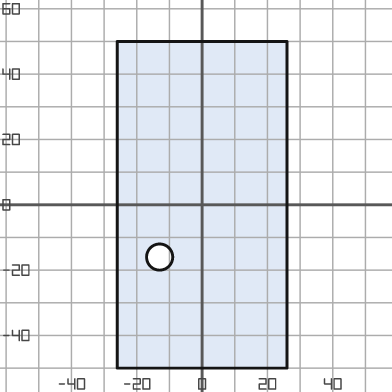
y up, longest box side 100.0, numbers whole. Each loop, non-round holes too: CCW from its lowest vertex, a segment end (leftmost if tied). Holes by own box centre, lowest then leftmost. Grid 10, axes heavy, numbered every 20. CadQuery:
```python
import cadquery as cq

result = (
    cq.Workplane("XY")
    .moveTo(-26.0, -50.0)
    .lineTo(26.0, -50.0)
    .lineTo(26.0, 50.0)
    .lineTo(-26.0, 50.0)
    .close()
    .moveTo(-13.0, -16.0)
    .circle(4.0)
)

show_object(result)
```